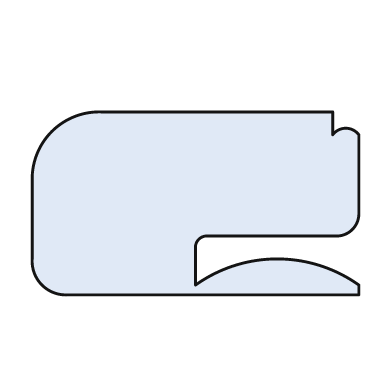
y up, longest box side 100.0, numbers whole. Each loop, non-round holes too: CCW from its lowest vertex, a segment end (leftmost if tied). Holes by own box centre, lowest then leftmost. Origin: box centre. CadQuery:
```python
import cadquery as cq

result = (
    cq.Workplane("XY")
    .moveTo(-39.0, -28.0)
    .lineTo(50.0, -28.0)
    .lineTo(50.0, -25.0)
    .threePointArc((25.0, -17.0), (0.0, -25.0))
    .lineTo(0.0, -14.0)
    .threePointArc((1.0, -11.0), (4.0, -10.0))
    .lineTo(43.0, -10.0)
    .threePointArc((48.0, -8.0), (50.0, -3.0))
    .lineTo(50.0, 21.0)
    .threePointArc((46.0, 23.0), (42.0, 21.0))
    .lineTo(42.0, 28.0)
    .lineTo(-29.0, 28.0)
    .threePointArc((-44.0, 22.0), (-50.0, 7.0))
    .lineTo(-50.0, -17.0)
    .threePointArc((-47.0, -25.0), (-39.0, -28.0))
    .close()
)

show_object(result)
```